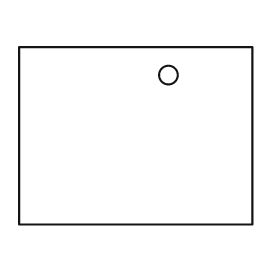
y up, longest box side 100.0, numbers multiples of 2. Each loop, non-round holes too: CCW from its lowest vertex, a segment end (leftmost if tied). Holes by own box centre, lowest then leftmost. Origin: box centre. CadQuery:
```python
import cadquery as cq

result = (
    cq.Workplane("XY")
    .moveTo(-50.0, -38.0)
    .lineTo(50.0, -38.0)
    .lineTo(50.0, 38.0)
    .lineTo(-50.0, 38.0)
    .close()
    .moveTo(14.0, 26.0)
    .circle(4.0)
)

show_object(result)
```